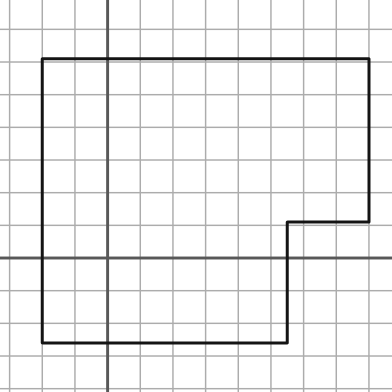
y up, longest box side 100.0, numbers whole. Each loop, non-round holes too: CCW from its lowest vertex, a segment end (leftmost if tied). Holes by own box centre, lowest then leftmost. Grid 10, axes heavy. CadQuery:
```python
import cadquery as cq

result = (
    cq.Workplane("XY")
    .moveTo(-20.0, -26.0)
    .lineTo(55.0, -26.0)
    .lineTo(55.0, 11.0)
    .lineTo(80.0, 11.0)
    .lineTo(80.0, 61.0)
    .lineTo(-20.0, 61.0)
    .close()
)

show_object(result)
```